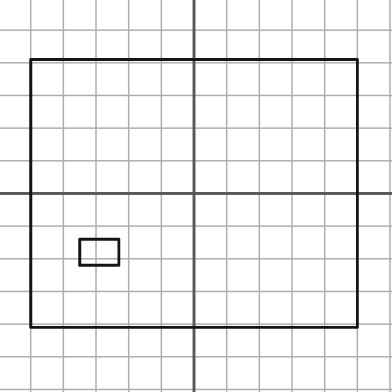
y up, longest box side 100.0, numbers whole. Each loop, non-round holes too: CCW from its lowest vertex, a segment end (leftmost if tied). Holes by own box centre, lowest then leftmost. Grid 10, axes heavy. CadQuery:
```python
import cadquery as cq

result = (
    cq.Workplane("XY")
    .moveTo(-50.0, -41.0)
    .lineTo(50.0, -41.0)
    .lineTo(50.0, 41.0)
    .lineTo(-50.0, 41.0)
    .close()
    .moveTo(-35.0, -22.0)
    .lineTo(-23.0, -22.0)
    .lineTo(-23.0, -14.0)
    .lineTo(-35.0, -14.0)
    .close()
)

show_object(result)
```